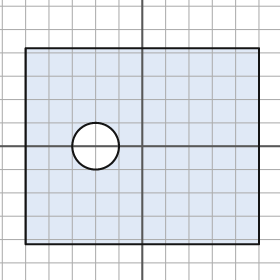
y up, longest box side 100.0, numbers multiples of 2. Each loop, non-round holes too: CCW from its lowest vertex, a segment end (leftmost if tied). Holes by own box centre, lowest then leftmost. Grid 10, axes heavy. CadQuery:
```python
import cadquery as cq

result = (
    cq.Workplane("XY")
    .moveTo(-50.0, -42.0)
    .lineTo(50.0, -42.0)
    .lineTo(50.0, 42.0)
    .lineTo(-50.0, 42.0)
    .close()
    .moveTo(-20.0, 0.0)
    .circle(10.0)
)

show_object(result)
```